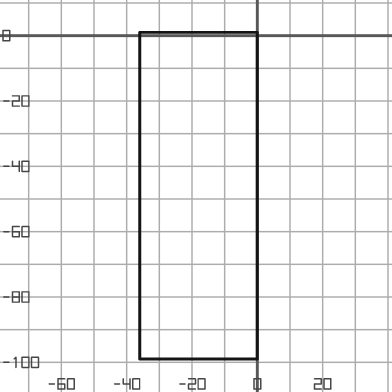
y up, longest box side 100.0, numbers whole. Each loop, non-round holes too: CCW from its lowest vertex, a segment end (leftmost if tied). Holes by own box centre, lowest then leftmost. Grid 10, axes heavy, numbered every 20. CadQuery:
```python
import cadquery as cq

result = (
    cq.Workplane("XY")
    .moveTo(-36.0, -99.0)
    .lineTo(0.0, -99.0)
    .lineTo(0.0, 1.0)
    .lineTo(-36.0, 1.0)
    .close()
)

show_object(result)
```